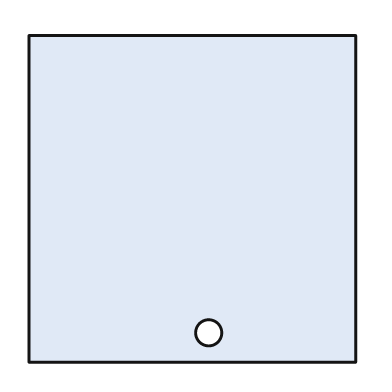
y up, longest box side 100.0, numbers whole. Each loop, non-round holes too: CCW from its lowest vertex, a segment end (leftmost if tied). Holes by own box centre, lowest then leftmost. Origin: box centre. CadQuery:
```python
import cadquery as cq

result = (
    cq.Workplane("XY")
    .moveTo(-50.0, -50.0)
    .lineTo(50.0, -50.0)
    .lineTo(50.0, 50.0)
    .lineTo(-50.0, 50.0)
    .close()
    .moveTo(5.0, -41.0)
    .circle(4.0)
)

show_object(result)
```